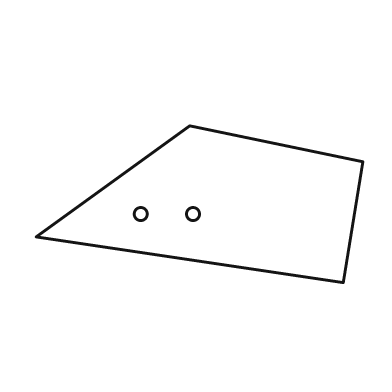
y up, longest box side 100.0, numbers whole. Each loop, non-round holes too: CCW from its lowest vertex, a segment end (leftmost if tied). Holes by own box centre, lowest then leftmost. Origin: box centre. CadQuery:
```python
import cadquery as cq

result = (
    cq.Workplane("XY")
    .moveTo(44.0, -24.0)
    .lineTo(50.0, 13.0)
    .lineTo(-3.0, 24.0)
    .lineTo(-50.0, -10.0)
    .close()
    .moveTo(-18.0, -3.0)
    .circle(2.0)
    .moveTo(-2.0, -3.0)
    .circle(2.0)
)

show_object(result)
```